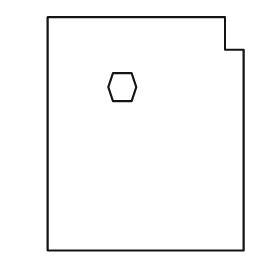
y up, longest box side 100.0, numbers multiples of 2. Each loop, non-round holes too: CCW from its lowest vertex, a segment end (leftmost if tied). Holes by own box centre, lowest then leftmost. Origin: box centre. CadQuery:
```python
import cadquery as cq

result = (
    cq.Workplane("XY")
    .moveTo(-42.0, -50.0)
    .lineTo(42.0, -50.0)
    .lineTo(42.0, 36.0)
    .lineTo(34.0, 36.0)
    .lineTo(34.0, 50.0)
    .lineTo(-42.0, 50.0)
    .close()
    .moveTo(-14.0, 14.0)
    .lineTo(-6.0, 14.0)
    .lineTo(-4.0, 20.0)
    .lineTo(-6.0, 26.0)
    .lineTo(-14.0, 26.0)
    .lineTo(-16.0, 20.0)
    .close()
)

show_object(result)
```